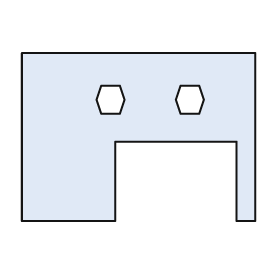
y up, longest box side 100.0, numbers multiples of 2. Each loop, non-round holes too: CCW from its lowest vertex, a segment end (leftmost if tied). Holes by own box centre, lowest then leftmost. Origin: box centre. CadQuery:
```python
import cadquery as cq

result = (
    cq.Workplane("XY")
    .moveTo(-50.0, -36.0)
    .lineTo(-10.0, -36.0)
    .lineTo(-10.0, -2.0)
    .lineTo(42.0, -2.0)
    .lineTo(42.0, -36.0)
    .lineTo(50.0, -36.0)
    .lineTo(50.0, 36.0)
    .lineTo(-50.0, 36.0)
    .close()
    .moveTo(-16.0, 10.0)
    .lineTo(-8.0, 10.0)
    .lineTo(-6.0, 16.0)
    .lineTo(-8.0, 22.0)
    .lineTo(-16.0, 22.0)
    .lineTo(-18.0, 16.0)
    .close()
    .moveTo(18.0, 10.0)
    .lineTo(26.0, 10.0)
    .lineTo(28.0, 16.0)
    .lineTo(26.0, 22.0)
    .lineTo(18.0, 22.0)
    .lineTo(16.0, 16.0)
    .close()
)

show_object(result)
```